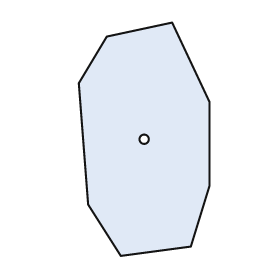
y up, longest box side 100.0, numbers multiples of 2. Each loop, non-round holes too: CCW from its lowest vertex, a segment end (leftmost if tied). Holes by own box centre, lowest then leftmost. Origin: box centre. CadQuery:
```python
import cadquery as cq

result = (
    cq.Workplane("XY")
    .moveTo(-10.0, -50.0)
    .lineTo(20.0, -46.0)
    .lineTo(28.0, -20.0)
    .lineTo(28.0, 16.0)
    .lineTo(12.0, 50.0)
    .lineTo(-16.0, 44.0)
    .lineTo(-28.0, 24.0)
    .lineTo(-24.0, -28.0)
    .close()
    .moveTo(0.0, 0.0)
    .circle(2.0)
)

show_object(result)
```